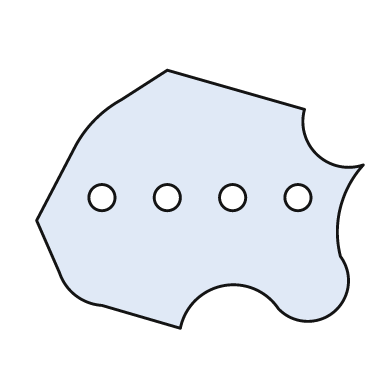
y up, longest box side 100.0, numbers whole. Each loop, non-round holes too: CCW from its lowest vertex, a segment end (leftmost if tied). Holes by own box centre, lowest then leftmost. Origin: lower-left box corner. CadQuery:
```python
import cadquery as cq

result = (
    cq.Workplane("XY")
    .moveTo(44.0, 0.0)
    .threePointArc((57.0, 13.0), (74.0, 6.0))
    .threePointArc((91.0, 5.0), (93.0, 22.0))
    .threePointArc((93.0, 37.0), (100.0, 50.0))
    .threePointArc((86.0, 53.0), (82.0, 67.0))
    .lineTo(40.0, 79.0)
    .lineTo(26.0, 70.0)
    .threePointArc((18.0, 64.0), (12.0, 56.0))
    .lineTo(0.0, 33.0)
    .lineTo(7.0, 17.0)
    .threePointArc((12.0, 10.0), (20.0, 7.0))
    .close()
    .moveTo(20.0, 40.0)
    .circle(4.0)
    .moveTo(40.0, 40.0)
    .circle(4.0)
    .moveTo(60.0, 40.0)
    .circle(4.0)
    .moveTo(80.0, 40.0)
    .circle(4.0)
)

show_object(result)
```